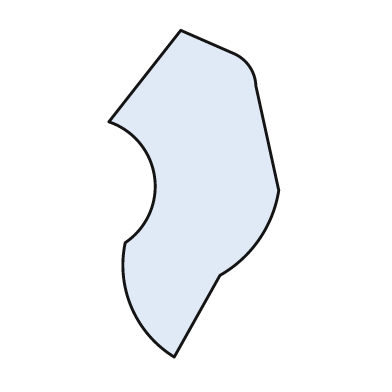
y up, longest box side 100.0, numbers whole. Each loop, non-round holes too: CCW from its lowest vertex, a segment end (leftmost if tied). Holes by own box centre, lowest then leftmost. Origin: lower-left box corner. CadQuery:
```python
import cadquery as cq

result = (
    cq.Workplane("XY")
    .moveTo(20.0, 0.0)
    .lineTo(34.0, 25.0)
    .threePointArc((46.0, 36.0), (52.0, 51.0))
    .lineTo(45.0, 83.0)
    .threePointArc((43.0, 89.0), (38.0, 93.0))
    .lineTo(22.0, 100.0)
    .lineTo(0.0, 72.0)
    .threePointArc((14.0, 55.0), (5.0, 35.0))
    .threePointArc((7.0, 15.0), (20.0, 0.0))
    .close()
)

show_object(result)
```